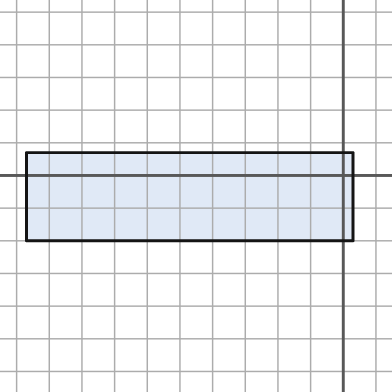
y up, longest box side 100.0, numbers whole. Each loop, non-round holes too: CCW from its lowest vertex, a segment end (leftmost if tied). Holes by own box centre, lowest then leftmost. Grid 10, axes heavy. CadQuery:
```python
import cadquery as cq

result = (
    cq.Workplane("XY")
    .moveTo(-97.0, -20.0)
    .lineTo(3.0, -20.0)
    .lineTo(3.0, 7.0)
    .lineTo(-97.0, 7.0)
    .close()
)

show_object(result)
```